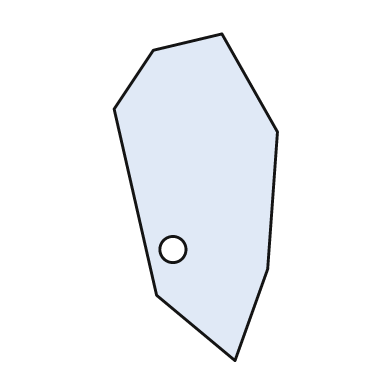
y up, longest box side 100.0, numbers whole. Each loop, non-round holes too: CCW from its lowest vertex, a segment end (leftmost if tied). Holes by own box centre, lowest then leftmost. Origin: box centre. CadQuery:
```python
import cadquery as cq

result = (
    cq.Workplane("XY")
    .moveTo(12.0, -50.0)
    .lineTo(22.0, -22.0)
    .lineTo(25.0, 20.0)
    .lineTo(8.0, 50.0)
    .lineTo(-13.0, 45.0)
    .lineTo(-25.0, 27.0)
    .lineTo(-12.0, -30.0)
    .close()
    .moveTo(-7.0, -16.0)
    .circle(4.0)
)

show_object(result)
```